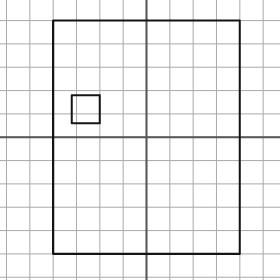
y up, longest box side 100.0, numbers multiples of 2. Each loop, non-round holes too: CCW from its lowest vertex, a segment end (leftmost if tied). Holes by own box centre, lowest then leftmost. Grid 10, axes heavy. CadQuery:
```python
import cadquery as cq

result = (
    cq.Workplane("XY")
    .moveTo(-40.0, -50.0)
    .lineTo(40.0, -50.0)
    .lineTo(40.0, 50.0)
    .lineTo(-40.0, 50.0)
    .close()
    .moveTo(-32.0, 6.0)
    .lineTo(-20.0, 6.0)
    .lineTo(-20.0, 18.0)
    .lineTo(-32.0, 18.0)
    .close()
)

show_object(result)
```